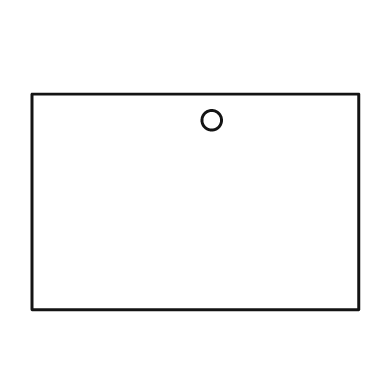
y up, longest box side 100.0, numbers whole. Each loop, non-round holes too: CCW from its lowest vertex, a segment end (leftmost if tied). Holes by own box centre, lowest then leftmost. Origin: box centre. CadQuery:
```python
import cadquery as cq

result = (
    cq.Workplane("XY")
    .moveTo(-50.0, -33.0)
    .lineTo(50.0, -33.0)
    .lineTo(50.0, 33.0)
    .lineTo(-50.0, 33.0)
    .close()
    .moveTo(5.0, 25.0)
    .circle(3.0)
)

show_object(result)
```